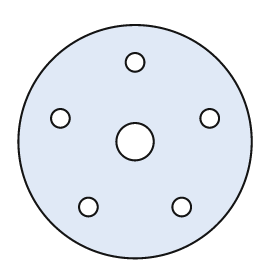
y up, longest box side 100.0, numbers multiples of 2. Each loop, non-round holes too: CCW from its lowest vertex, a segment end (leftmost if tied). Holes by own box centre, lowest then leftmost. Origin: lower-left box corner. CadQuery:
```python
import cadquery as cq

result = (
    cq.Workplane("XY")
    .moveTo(50.0, 50.0)
    .circle(50.0)
    .moveTo(30.0, 22.0)
    .circle(4.0)
    .moveTo(70.0, 22.0)
    .circle(4.0)
    .moveTo(50.0, 50.0)
    .circle(8.0)
    .moveTo(18.0, 60.0)
    .circle(4.0)
    .moveTo(82.0, 60.0)
    .circle(4.0)
    .moveTo(50.0, 84.0)
    .circle(4.0)
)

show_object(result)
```